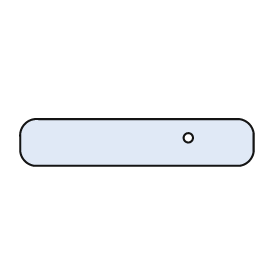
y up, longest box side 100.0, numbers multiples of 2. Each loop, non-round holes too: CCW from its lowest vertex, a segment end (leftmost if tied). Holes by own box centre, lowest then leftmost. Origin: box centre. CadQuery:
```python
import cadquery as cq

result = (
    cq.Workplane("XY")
    .moveTo(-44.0, -10.0)
    .lineTo(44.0, -10.0)
    .threePointArc((48.0, -8.0), (50.0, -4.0))
    .lineTo(50.0, 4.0)
    .threePointArc((48.0, 8.0), (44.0, 10.0))
    .lineTo(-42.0, 10.0)
    .threePointArc((-48.0, 8.0), (-50.0, 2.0))
    .lineTo(-50.0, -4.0)
    .threePointArc((-48.0, -8.0), (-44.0, -10.0))
    .close()
    .moveTo(22.0, 2.0)
    .circle(2.0)
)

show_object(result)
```